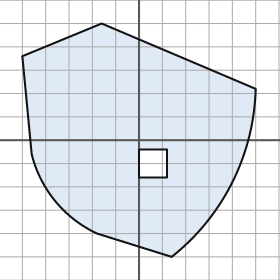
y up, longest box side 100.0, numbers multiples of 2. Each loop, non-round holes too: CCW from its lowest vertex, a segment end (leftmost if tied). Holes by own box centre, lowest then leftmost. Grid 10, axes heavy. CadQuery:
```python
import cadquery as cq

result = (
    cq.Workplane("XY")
    .moveTo(14.0, -50.0)
    .threePointArc((40.0, -18.0), (50.0, 22.0))
    .lineTo(-16.0, 50.0)
    .lineTo(-50.0, 36.0)
    .lineTo(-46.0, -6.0)
    .threePointArc((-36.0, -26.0), (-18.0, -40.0))
    .close()
    .moveTo(0.0, -16.0)
    .lineTo(12.0, -16.0)
    .lineTo(12.0, -4.0)
    .lineTo(0.0, -4.0)
    .close()
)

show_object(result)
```